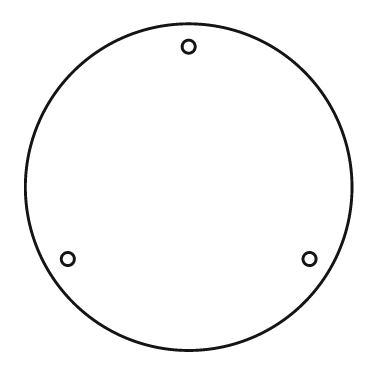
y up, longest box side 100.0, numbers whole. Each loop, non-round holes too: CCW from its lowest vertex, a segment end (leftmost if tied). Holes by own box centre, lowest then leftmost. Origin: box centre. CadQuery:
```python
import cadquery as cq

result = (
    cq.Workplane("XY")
    .moveTo(0.0, 0.0)
    .circle(50.0)
    .moveTo(-37.0, -22.0)
    .circle(2.0)
    .moveTo(37.0, -22.0)
    .circle(2.0)
    .moveTo(0.0, 43.0)
    .circle(2.0)
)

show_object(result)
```